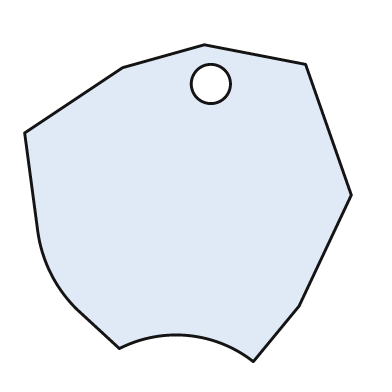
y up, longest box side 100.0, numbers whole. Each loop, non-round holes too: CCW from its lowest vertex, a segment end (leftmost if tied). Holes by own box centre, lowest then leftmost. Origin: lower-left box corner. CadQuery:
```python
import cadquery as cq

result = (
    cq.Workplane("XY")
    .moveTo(70.0, 0.0)
    .lineTo(84.0, 17.0)
    .lineTo(100.0, 51.0)
    .lineTo(86.0, 91.0)
    .lineTo(55.0, 97.0)
    .lineTo(30.0, 90.0)
    .lineTo(0.0, 70.0)
    .lineTo(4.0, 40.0)
    .threePointArc((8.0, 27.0), (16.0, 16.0))
    .lineTo(29.0, 4.0)
    .threePointArc((50.0, 8.0), (70.0, 0.0))
    .close()
    .moveTo(57.0, 85.0)
    .circle(6.0)
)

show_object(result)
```